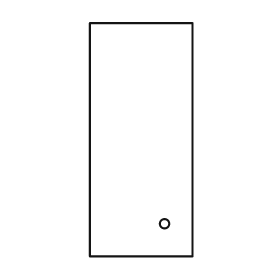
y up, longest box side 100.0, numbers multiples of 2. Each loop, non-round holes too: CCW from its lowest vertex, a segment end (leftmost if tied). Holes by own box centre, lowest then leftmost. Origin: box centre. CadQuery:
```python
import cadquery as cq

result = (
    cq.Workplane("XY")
    .moveTo(-22.0, -50.0)
    .lineTo(22.0, -50.0)
    .lineTo(22.0, 50.0)
    .lineTo(-22.0, 50.0)
    .close()
    .moveTo(10.0, -36.0)
    .circle(2.0)
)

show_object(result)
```